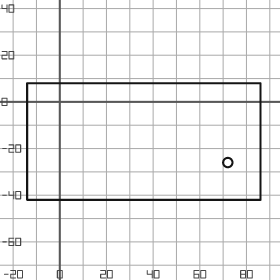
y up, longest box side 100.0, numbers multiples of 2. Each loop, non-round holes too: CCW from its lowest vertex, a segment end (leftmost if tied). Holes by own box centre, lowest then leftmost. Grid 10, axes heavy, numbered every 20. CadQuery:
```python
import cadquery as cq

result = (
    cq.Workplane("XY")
    .moveTo(-14.0, -42.0)
    .lineTo(86.0, -42.0)
    .lineTo(86.0, 8.0)
    .lineTo(-14.0, 8.0)
    .close()
    .moveTo(72.0, -26.0)
    .circle(2.0)
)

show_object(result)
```